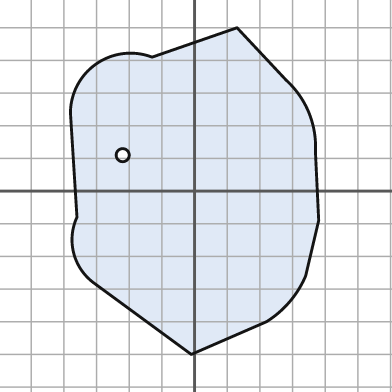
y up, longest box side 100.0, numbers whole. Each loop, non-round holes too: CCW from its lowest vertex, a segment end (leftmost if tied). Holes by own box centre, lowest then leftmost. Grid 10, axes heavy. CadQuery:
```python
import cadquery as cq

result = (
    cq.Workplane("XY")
    .moveTo(-1.0, -50.0)
    .lineTo(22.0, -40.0)
    .threePointArc((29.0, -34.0), (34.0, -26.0))
    .lineTo(38.0, -9.0)
    .lineTo(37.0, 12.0)
    .threePointArc((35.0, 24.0), (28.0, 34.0))
    .lineTo(13.0, 50.0)
    .lineTo(-13.0, 41.0)
    .threePointArc((-30.0, 39.0), (-38.0, 24.0))
    .lineTo(-36.0, -8.0)
    .threePointArc((-37.0, -19.0), (-31.0, -28.0))
    .close()
    .moveTo(-22.0, 11.0)
    .circle(2.0)
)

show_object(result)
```